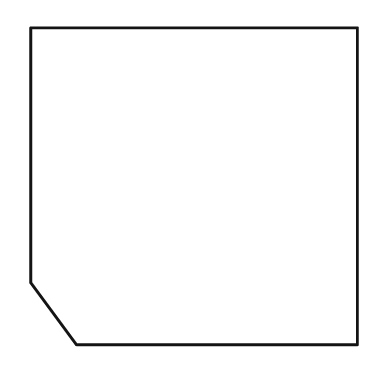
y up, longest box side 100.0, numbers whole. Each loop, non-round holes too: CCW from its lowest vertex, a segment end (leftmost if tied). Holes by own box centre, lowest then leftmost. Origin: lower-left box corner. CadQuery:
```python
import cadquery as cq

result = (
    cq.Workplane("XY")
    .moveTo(14.0, 0.0)
    .lineTo(100.0, 0.0)
    .lineTo(100.0, 97.0)
    .lineTo(0.0, 97.0)
    .lineTo(0.0, 19.0)
    .close()
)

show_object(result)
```